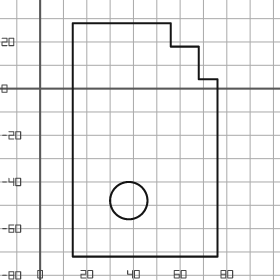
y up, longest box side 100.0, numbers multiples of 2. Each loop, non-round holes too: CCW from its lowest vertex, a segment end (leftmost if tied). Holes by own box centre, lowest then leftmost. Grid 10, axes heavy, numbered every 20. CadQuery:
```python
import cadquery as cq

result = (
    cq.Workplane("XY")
    .moveTo(14.0, -72.0)
    .lineTo(76.0, -72.0)
    .lineTo(76.0, 4.0)
    .lineTo(68.0, 4.0)
    .lineTo(68.0, 18.0)
    .lineTo(56.0, 18.0)
    .lineTo(56.0, 28.0)
    .lineTo(14.0, 28.0)
    .close()
    .moveTo(38.0, -48.0)
    .circle(8.0)
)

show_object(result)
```